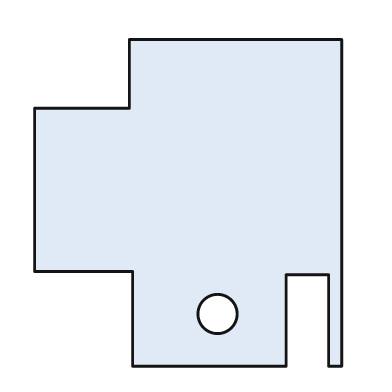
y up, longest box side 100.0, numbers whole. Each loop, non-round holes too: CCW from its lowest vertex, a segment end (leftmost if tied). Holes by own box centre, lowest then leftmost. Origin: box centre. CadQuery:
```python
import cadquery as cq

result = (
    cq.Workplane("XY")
    .moveTo(-17.0, -50.0)
    .lineTo(30.0, -50.0)
    .lineTo(30.0, -22.0)
    .lineTo(43.0, -22.0)
    .lineTo(43.0, -50.0)
    .lineTo(47.0, -50.0)
    .lineTo(47.0, 50.0)
    .lineTo(-18.0, 50.0)
    .lineTo(-18.0, 29.0)
    .lineTo(-47.0, 29.0)
    .lineTo(-47.0, -21.0)
    .lineTo(-17.0, -21.0)
    .close()
    .moveTo(9.0, -34.0)
    .circle(6.0)
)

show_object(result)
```